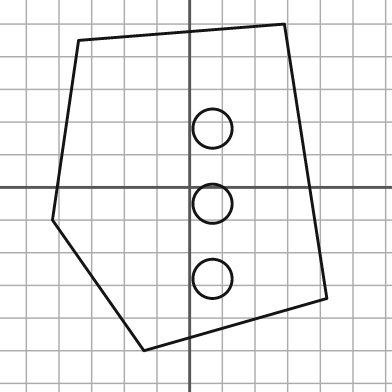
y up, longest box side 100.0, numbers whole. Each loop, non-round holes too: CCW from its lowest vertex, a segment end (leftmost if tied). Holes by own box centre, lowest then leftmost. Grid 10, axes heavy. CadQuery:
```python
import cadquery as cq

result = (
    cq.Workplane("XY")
    .moveTo(-14.0, -50.0)
    .lineTo(42.0, -34.0)
    .lineTo(29.0, 50.0)
    .lineTo(-34.0, 45.0)
    .lineTo(-42.0, -10.0)
    .close()
    .moveTo(7.0, -28.0)
    .circle(6.0)
    .moveTo(7.0, -5.0)
    .circle(6.0)
    .moveTo(7.0, 18.0)
    .circle(6.0)
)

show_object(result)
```